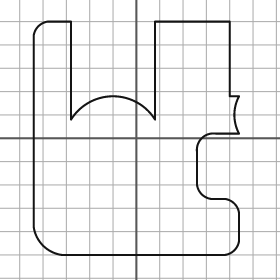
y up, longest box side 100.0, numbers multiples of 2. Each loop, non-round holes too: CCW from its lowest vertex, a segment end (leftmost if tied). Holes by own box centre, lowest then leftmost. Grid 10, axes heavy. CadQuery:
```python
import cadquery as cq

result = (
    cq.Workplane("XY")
    .moveTo(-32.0, -50.0)
    .lineTo(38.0, -50.0)
    .threePointArc((42.0, -48.0), (44.0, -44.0))
    .lineTo(44.0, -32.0)
    .threePointArc((42.0, -28.0), (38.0, -26.0))
    .lineTo(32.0, -26.0)
    .threePointArc((28.0, -24.0), (26.0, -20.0))
    .lineTo(26.0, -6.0)
    .threePointArc((28.0, 0.0), (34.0, 2.0))
    .lineTo(44.0, 2.0)
    .threePointArc((42.0, 10.0), (44.0, 18.0))
    .lineTo(40.0, 18.0)
    .lineTo(40.0, 50.0)
    .lineTo(8.0, 50.0)
    .lineTo(8.0, 8.0)
    .threePointArc((-10.0, 18.0), (-28.0, 8.0))
    .lineTo(-28.0, 50.0)
    .lineTo(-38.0, 50.0)
    .threePointArc((-42.0, 48.0), (-44.0, 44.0))
    .lineTo(-44.0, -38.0)
    .threePointArc((-40.0, -46.0), (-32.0, -50.0))
    .close()
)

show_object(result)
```